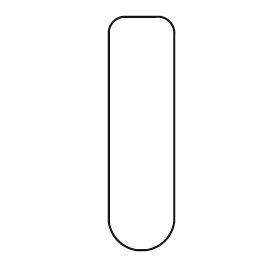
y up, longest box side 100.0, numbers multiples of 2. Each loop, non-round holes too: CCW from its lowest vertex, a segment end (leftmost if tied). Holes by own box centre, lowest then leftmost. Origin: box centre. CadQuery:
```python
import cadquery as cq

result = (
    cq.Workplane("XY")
    .moveTo(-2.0, -50.0)
    .lineTo(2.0, -50.0)
    .threePointArc((10.0, -46.0), (14.0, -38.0))
    .lineTo(14.0, 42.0)
    .threePointArc((12.0, 48.0), (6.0, 50.0))
    .lineTo(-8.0, 50.0)
    .threePointArc((-12.0, 48.0), (-14.0, 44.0))
    .lineTo(-14.0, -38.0)
    .threePointArc((-10.0, -46.0), (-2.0, -50.0))
    .close()
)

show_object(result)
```